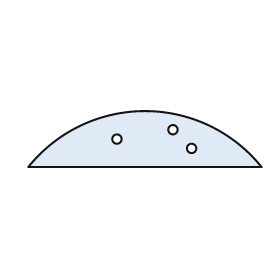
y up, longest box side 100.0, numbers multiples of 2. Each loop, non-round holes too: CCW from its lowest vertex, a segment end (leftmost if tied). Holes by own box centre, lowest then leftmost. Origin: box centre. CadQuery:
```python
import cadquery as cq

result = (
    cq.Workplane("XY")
    .moveTo(-50.0, -12.0)
    .lineTo(50.0, -12.0)
    .threePointArc((0.0, 12.0), (-50.0, -12.0))
    .close()
    .moveTo(20.0, -4.0)
    .circle(2.0)
    .moveTo(-12.0, 0.0)
    .circle(2.0)
    .moveTo(12.0, 4.0)
    .circle(2.0)
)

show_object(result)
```